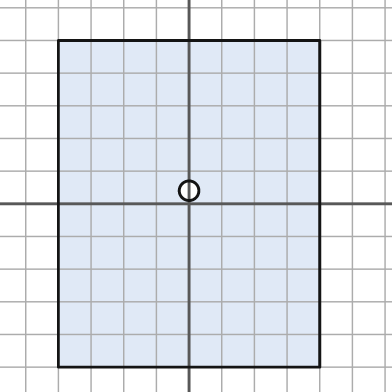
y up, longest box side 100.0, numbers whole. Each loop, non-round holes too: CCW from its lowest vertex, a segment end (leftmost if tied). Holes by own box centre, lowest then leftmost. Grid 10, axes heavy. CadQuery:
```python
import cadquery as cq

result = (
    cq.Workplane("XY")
    .moveTo(-40.0, -50.0)
    .lineTo(40.0, -50.0)
    .lineTo(40.0, 50.0)
    .lineTo(-40.0, 50.0)
    .close()
    .moveTo(0.0, 4.0)
    .circle(3.0)
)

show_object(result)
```